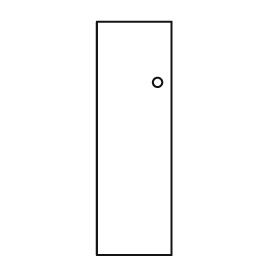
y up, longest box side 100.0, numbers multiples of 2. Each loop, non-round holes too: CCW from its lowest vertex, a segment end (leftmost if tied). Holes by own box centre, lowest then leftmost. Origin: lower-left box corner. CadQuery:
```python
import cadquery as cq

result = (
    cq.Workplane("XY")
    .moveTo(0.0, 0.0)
    .lineTo(32.0, 0.0)
    .lineTo(32.0, 100.0)
    .lineTo(0.0, 100.0)
    .close()
    .moveTo(26.0, 74.0)
    .circle(2.0)
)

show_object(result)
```